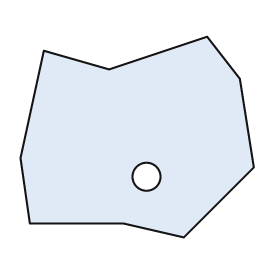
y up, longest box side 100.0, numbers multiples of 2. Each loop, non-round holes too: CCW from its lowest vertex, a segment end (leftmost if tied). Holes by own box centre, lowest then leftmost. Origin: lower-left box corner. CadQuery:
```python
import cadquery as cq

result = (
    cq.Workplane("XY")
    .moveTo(70.0, 0.0)
    .lineTo(100.0, 30.0)
    .lineTo(94.0, 68.0)
    .lineTo(80.0, 86.0)
    .lineTo(38.0, 72.0)
    .lineTo(10.0, 80.0)
    .lineTo(0.0, 34.0)
    .lineTo(4.0, 6.0)
    .lineTo(44.0, 6.0)
    .close()
    .moveTo(54.0, 26.0)
    .circle(6.0)
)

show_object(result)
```